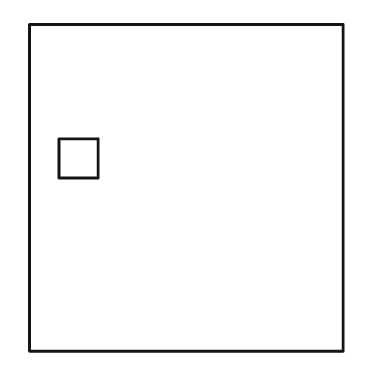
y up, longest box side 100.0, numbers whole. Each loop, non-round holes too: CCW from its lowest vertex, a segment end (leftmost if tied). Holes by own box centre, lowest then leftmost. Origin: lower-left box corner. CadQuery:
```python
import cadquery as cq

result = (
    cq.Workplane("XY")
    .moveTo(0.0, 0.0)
    .lineTo(96.0, 0.0)
    .lineTo(96.0, 100.0)
    .lineTo(0.0, 100.0)
    .close()
    .moveTo(9.0, 53.0)
    .lineTo(21.0, 53.0)
    .lineTo(21.0, 65.0)
    .lineTo(9.0, 65.0)
    .close()
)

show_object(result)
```